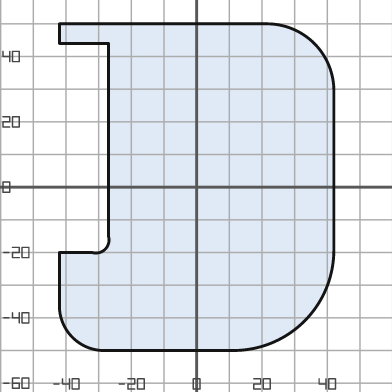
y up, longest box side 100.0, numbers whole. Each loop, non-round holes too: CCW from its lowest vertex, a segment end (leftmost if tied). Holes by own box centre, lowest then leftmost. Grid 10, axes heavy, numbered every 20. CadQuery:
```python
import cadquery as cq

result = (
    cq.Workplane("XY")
    .moveTo(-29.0, -50.0)
    .lineTo(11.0, -50.0)
    .threePointArc((33.0, -41.0), (42.0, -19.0))
    .lineTo(42.0, 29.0)
    .threePointArc((36.0, 44.0), (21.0, 50.0))
    .lineTo(-42.0, 50.0)
    .lineTo(-42.0, 44.0)
    .lineTo(-27.0, 44.0)
    .lineTo(-27.0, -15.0)
    .threePointArc((-28.0, -19.0), (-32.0, -20.0))
    .lineTo(-42.0, -20.0)
    .lineTo(-42.0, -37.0)
    .threePointArc((-38.0, -46.0), (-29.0, -50.0))
    .close()
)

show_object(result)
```